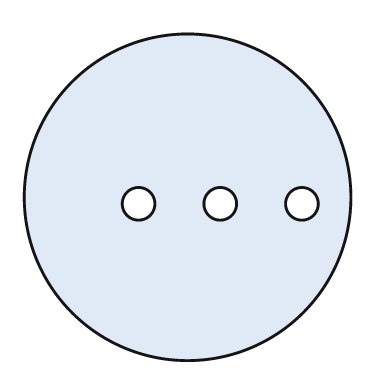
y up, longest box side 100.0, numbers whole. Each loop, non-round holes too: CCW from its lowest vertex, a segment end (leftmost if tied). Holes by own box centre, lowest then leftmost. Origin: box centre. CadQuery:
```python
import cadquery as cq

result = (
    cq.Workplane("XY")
    .moveTo(0.0, 0.0)
    .circle(50.0)
    .moveTo(-15.0, -2.0)
    .circle(5.0)
    .moveTo(10.0, -2.0)
    .circle(5.0)
    .moveTo(35.0, -2.0)
    .circle(5.0)
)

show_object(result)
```